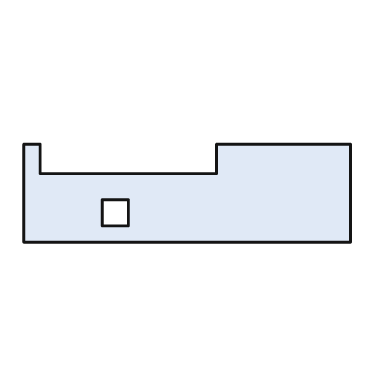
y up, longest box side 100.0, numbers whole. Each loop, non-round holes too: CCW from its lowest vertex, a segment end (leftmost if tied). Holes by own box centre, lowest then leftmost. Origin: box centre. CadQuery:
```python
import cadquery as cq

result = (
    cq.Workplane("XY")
    .moveTo(-50.0, -15.0)
    .lineTo(50.0, -15.0)
    .lineTo(50.0, 15.0)
    .lineTo(9.0, 15.0)
    .lineTo(9.0, 6.0)
    .lineTo(-45.0, 6.0)
    .lineTo(-45.0, 15.0)
    .lineTo(-50.0, 15.0)
    .close()
    .moveTo(-26.0, -10.0)
    .lineTo(-18.0, -10.0)
    .lineTo(-18.0, -2.0)
    .lineTo(-26.0, -2.0)
    .close()
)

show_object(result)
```